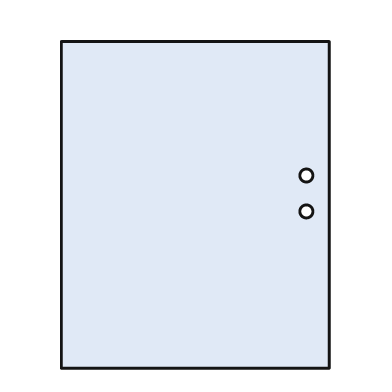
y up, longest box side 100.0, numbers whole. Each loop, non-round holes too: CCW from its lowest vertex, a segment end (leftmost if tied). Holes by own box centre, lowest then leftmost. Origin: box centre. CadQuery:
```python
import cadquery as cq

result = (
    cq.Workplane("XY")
    .moveTo(-41.0, -50.0)
    .lineTo(41.0, -50.0)
    .lineTo(41.0, 50.0)
    .lineTo(-41.0, 50.0)
    .close()
    .moveTo(34.0, -2.0)
    .circle(2.0)
    .moveTo(34.0, 9.0)
    .circle(2.0)
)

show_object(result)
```